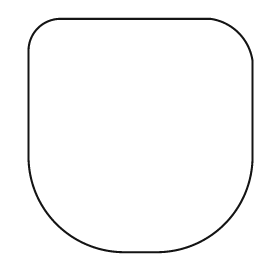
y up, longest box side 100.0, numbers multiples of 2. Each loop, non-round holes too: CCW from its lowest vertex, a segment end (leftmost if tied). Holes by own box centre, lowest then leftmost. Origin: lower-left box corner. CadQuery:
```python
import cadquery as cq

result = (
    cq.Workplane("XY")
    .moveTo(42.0, 0.0)
    .lineTo(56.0, 0.0)
    .threePointArc((84.0, 12.0), (96.0, 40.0))
    .lineTo(96.0, 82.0)
    .threePointArc((90.0, 94.0), (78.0, 100.0))
    .lineTo(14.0, 100.0)
    .threePointArc((4.0, 96.0), (0.0, 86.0))
    .lineTo(0.0, 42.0)
    .threePointArc((12.0, 12.0), (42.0, 0.0))
    .close()
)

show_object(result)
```